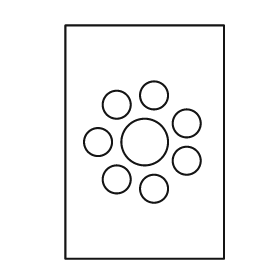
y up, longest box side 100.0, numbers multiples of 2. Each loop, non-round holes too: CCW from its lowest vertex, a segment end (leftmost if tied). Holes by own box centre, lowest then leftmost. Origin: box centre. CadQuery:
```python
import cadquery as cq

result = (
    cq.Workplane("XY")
    .moveTo(-34.0, -50.0)
    .lineTo(34.0, -50.0)
    .lineTo(34.0, 50.0)
    .lineTo(-34.0, 50.0)
    .close()
    .moveTo(4.0, -20.0)
    .circle(6.0)
    .moveTo(-12.0, -16.0)
    .circle(6.0)
    .moveTo(18.0, -8.0)
    .circle(6.0)
    .moveTo(-20.0, 0.0)
    .circle(6.0)
    .moveTo(0.0, 0.0)
    .circle(10.0)
    .moveTo(18.0, 8.0)
    .circle(6.0)
    .moveTo(-12.0, 16.0)
    .circle(6.0)
    .moveTo(4.0, 20.0)
    .circle(6.0)
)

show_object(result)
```